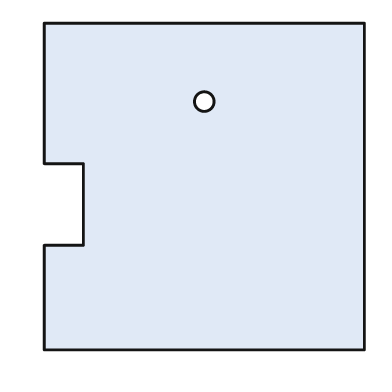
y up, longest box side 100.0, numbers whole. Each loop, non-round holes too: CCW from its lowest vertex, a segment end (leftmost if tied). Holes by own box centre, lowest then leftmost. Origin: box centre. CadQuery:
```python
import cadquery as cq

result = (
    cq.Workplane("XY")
    .moveTo(-49.0, -50.0)
    .lineTo(49.0, -50.0)
    .lineTo(49.0, 50.0)
    .lineTo(-49.0, 50.0)
    .lineTo(-49.0, 7.0)
    .lineTo(-37.0, 7.0)
    .lineTo(-37.0, -18.0)
    .lineTo(-49.0, -18.0)
    .close()
    .moveTo(0.0, 26.0)
    .circle(3.0)
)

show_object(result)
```